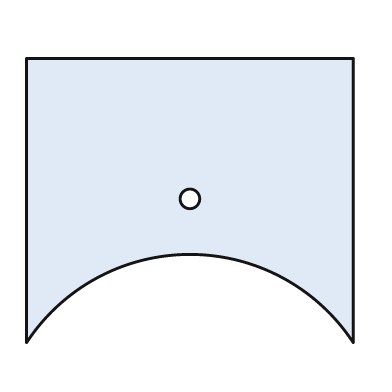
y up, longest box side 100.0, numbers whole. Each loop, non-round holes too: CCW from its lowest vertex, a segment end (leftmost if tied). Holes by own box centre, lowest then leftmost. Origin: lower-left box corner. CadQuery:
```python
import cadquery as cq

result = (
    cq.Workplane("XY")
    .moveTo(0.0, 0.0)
    .threePointArc((50.0, 27.0), (100.0, 0.0))
    .lineTo(100.0, 87.0)
    .lineTo(0.0, 87.0)
    .close()
    .moveTo(50.0, 44.0)
    .circle(3.0)
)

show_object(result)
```